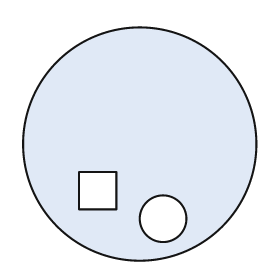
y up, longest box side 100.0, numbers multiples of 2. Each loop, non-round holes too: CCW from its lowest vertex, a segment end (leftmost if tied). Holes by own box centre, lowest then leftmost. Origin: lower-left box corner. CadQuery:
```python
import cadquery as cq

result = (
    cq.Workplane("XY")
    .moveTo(50.0, 50.0)
    .circle(50.0)
    .moveTo(60.0, 18.0)
    .circle(10.0)
    .moveTo(24.0, 22.0)
    .lineTo(40.0, 22.0)
    .lineTo(40.0, 38.0)
    .lineTo(24.0, 38.0)
    .close()
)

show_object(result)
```